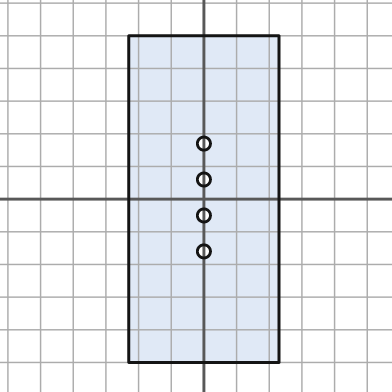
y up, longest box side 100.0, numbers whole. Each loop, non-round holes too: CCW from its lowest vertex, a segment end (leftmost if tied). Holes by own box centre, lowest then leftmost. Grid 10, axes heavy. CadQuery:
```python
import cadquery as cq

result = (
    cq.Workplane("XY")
    .moveTo(-23.0, -50.0)
    .lineTo(23.0, -50.0)
    .lineTo(23.0, 50.0)
    .lineTo(-23.0, 50.0)
    .close()
    .moveTo(0.0, -16.0)
    .circle(2.0)
    .moveTo(0.0, -5.0)
    .circle(2.0)
    .moveTo(0.0, 6.0)
    .circle(2.0)
    .moveTo(0.0, 17.0)
    .circle(2.0)
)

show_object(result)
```